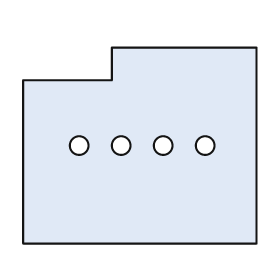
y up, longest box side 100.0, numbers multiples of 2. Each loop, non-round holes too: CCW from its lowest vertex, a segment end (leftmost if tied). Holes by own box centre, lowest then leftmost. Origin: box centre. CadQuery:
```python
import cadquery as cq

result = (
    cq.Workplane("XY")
    .moveTo(-50.0, -42.0)
    .lineTo(50.0, -42.0)
    .lineTo(50.0, 42.0)
    .lineTo(-12.0, 42.0)
    .lineTo(-12.0, 28.0)
    .lineTo(-50.0, 28.0)
    .close()
    .moveTo(-26.0, 0.0)
    .circle(4.0)
    .moveTo(-8.0, 0.0)
    .circle(4.0)
    .moveTo(10.0, 0.0)
    .circle(4.0)
    .moveTo(28.0, 0.0)
    .circle(4.0)
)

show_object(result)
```